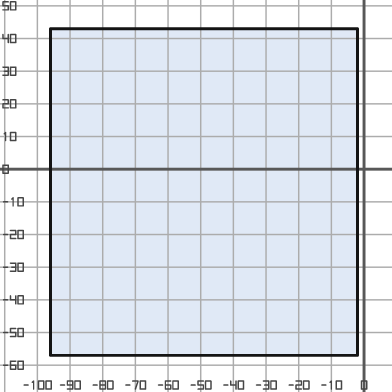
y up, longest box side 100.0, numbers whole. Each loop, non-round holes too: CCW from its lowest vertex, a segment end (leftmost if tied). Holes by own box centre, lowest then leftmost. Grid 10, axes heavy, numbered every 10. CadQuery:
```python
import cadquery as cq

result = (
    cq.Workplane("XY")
    .moveTo(-96.0, -57.0)
    .lineTo(-2.0, -57.0)
    .lineTo(-2.0, 43.0)
    .lineTo(-96.0, 43.0)
    .close()
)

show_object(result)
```